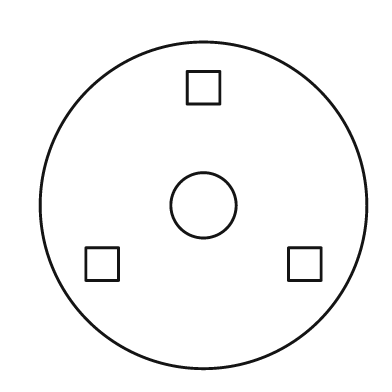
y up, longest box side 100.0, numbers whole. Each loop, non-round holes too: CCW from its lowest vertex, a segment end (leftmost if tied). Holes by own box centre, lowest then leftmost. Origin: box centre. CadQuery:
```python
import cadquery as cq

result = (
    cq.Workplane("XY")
    .moveTo(0.0, 0.0)
    .circle(50.0)
    .moveTo(-36.0, -23.0)
    .lineTo(-26.0, -23.0)
    .lineTo(-26.0, -13.0)
    .lineTo(-36.0, -13.0)
    .close()
    .moveTo(26.0, -23.0)
    .lineTo(36.0, -23.0)
    .lineTo(36.0, -13.0)
    .lineTo(26.0, -13.0)
    .close()
    .moveTo(0.0, 0.0)
    .circle(10.0)
    .moveTo(-5.0, 31.0)
    .lineTo(5.0, 31.0)
    .lineTo(5.0, 41.0)
    .lineTo(-5.0, 41.0)
    .close()
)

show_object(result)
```